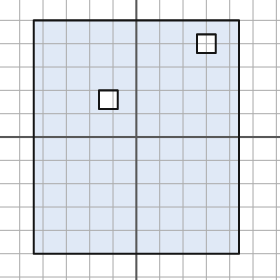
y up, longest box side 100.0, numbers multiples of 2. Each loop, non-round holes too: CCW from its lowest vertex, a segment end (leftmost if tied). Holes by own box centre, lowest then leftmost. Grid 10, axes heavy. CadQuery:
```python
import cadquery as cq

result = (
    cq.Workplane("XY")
    .moveTo(-44.0, -50.0)
    .lineTo(44.0, -50.0)
    .lineTo(44.0, 50.0)
    .lineTo(-44.0, 50.0)
    .close()
    .moveTo(-16.0, 12.0)
    .lineTo(-8.0, 12.0)
    .lineTo(-8.0, 20.0)
    .lineTo(-16.0, 20.0)
    .close()
    .moveTo(26.0, 36.0)
    .lineTo(34.0, 36.0)
    .lineTo(34.0, 44.0)
    .lineTo(26.0, 44.0)
    .close()
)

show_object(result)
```